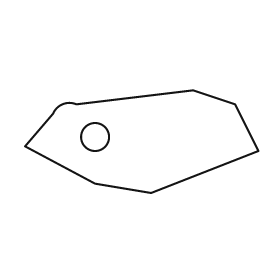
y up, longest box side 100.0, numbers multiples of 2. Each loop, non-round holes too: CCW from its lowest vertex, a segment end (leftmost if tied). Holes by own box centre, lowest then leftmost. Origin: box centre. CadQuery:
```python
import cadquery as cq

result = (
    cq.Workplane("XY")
    .moveTo(4.0, -22.0)
    .lineTo(50.0, -4.0)
    .lineTo(40.0, 16.0)
    .lineTo(22.0, 22.0)
    .lineTo(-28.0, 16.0)
    .threePointArc((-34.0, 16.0), (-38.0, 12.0))
    .lineTo(-50.0, -2.0)
    .lineTo(-20.0, -18.0)
    .close()
    .moveTo(-20.0, 2.0)
    .circle(6.0)
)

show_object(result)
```